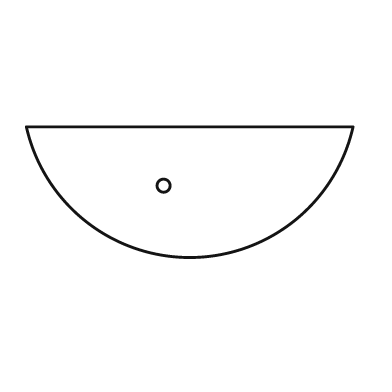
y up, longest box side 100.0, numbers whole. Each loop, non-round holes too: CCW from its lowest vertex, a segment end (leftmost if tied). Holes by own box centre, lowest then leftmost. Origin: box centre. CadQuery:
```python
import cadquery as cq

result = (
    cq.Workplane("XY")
    .moveTo(-50.0, 20.0)
    .threePointArc((0.0, -20.0), (50.0, 20.0))
    .close()
    .moveTo(-8.0, 2.0)
    .circle(2.0)
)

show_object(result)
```